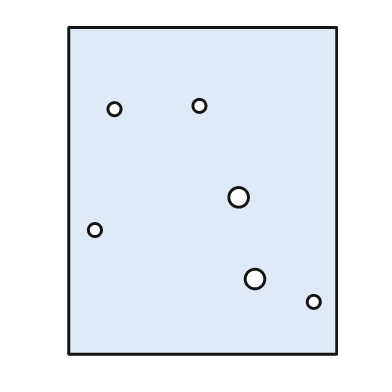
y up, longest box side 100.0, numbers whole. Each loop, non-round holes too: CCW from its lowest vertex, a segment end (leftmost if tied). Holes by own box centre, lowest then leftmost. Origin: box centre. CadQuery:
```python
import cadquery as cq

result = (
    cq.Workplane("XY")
    .moveTo(-41.0, -50.0)
    .lineTo(41.0, -50.0)
    .lineTo(41.0, 50.0)
    .lineTo(-41.0, 50.0)
    .close()
    .moveTo(34.0, -34.0)
    .circle(2.0)
    .moveTo(16.0, -27.0)
    .circle(3.0)
    .moveTo(-33.0, -12.0)
    .circle(2.0)
    .moveTo(11.0, -2.0)
    .circle(3.0)
    .moveTo(-27.0, 25.0)
    .circle(2.0)
    .moveTo(-1.0, 26.0)
    .circle(2.0)
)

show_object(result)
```